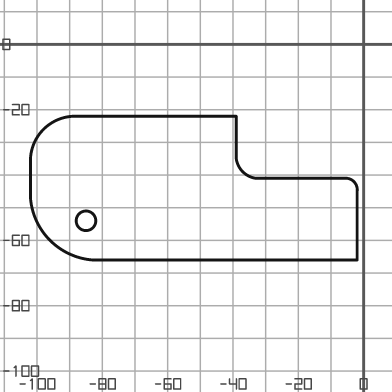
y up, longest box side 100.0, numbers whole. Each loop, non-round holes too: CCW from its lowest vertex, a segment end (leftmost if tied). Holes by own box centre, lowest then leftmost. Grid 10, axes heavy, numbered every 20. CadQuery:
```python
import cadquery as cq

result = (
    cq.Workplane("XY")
    .moveTo(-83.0, -66.0)
    .lineTo(-2.0, -66.0)
    .lineTo(-2.0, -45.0)
    .threePointArc((-3.0, -42.0), (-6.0, -41.0))
    .lineTo(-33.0, -41.0)
    .threePointArc((-37.0, -39.0), (-39.0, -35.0))
    .lineTo(-39.0, -22.0)
    .lineTo(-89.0, -22.0)
    .threePointArc((-98.0, -26.0), (-102.0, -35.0))
    .lineTo(-102.0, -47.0)
    .threePointArc((-96.0, -60.0), (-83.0, -66.0))
    .close()
    .moveTo(-85.0, -54.0)
    .circle(3.0)
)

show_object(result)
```